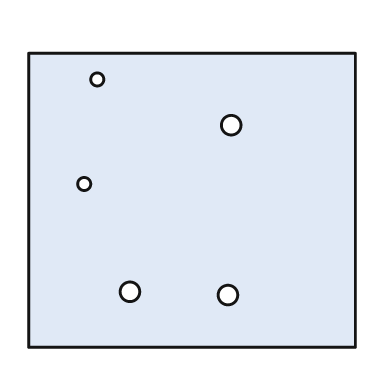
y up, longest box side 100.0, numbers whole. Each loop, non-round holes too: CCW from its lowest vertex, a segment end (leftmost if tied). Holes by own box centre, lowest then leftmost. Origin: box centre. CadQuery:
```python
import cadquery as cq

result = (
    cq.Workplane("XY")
    .moveTo(-50.0, -45.0)
    .lineTo(50.0, -45.0)
    .lineTo(50.0, 45.0)
    .lineTo(-50.0, 45.0)
    .close()
    .moveTo(11.0, -29.0)
    .circle(3.0)
    .moveTo(-19.0, -28.0)
    .circle(3.0)
    .moveTo(-33.0, 5.0)
    .circle(2.0)
    .moveTo(12.0, 23.0)
    .circle(3.0)
    .moveTo(-29.0, 37.0)
    .circle(2.0)
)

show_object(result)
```